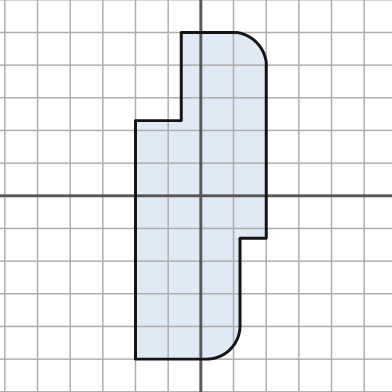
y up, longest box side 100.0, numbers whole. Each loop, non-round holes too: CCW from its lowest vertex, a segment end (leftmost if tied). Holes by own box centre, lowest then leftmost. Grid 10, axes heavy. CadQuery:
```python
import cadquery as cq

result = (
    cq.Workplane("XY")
    .moveTo(-20.0, -50.0)
    .lineTo(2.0, -50.0)
    .threePointArc((9.0, -47.0), (12.0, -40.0))
    .lineTo(12.0, -13.0)
    .lineTo(20.0, -13.0)
    .lineTo(20.0, 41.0)
    .threePointArc((17.0, 47.0), (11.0, 50.0))
    .lineTo(-6.0, 50.0)
    .lineTo(-6.0, 23.0)
    .lineTo(-20.0, 23.0)
    .close()
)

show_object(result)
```